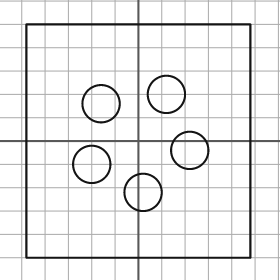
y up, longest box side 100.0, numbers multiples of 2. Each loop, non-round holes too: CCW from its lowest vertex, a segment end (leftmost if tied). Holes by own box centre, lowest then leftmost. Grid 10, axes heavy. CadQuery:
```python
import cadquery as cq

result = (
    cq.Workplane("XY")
    .moveTo(-48.0, -50.0)
    .lineTo(48.0, -50.0)
    .lineTo(48.0, 50.0)
    .lineTo(-48.0, 50.0)
    .close()
    .moveTo(2.0, -22.0)
    .circle(8.0)
    .moveTo(-20.0, -10.0)
    .circle(8.0)
    .moveTo(22.0, -4.0)
    .circle(8.0)
    .moveTo(-16.0, 16.0)
    .circle(8.0)
    .moveTo(12.0, 20.0)
    .circle(8.0)
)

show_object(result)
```